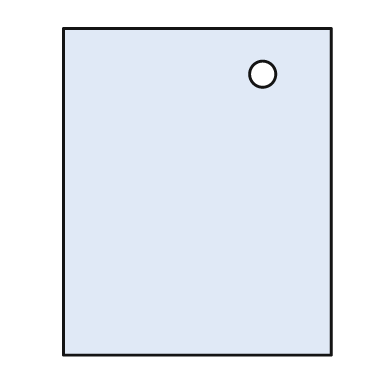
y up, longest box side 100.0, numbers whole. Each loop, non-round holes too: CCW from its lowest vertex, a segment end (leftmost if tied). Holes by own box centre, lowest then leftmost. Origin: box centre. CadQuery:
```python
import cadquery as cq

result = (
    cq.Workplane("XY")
    .moveTo(-41.0, -50.0)
    .lineTo(41.0, -50.0)
    .lineTo(41.0, 50.0)
    .lineTo(-41.0, 50.0)
    .close()
    .moveTo(20.0, 36.0)
    .circle(4.0)
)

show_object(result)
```